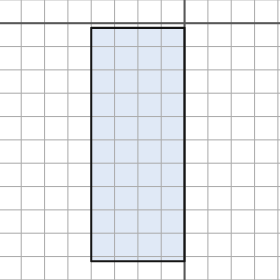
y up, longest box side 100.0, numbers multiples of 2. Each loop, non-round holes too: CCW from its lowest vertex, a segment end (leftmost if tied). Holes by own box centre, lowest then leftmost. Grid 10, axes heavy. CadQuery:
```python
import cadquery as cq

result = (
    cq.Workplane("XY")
    .moveTo(-40.0, -102.0)
    .lineTo(0.0, -102.0)
    .lineTo(0.0, -2.0)
    .lineTo(-40.0, -2.0)
    .close()
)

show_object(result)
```